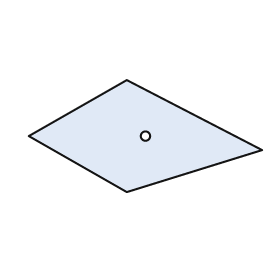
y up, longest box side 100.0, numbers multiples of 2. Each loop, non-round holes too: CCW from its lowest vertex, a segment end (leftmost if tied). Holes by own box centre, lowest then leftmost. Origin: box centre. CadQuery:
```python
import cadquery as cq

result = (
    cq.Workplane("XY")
    .moveTo(-8.0, -24.0)
    .lineTo(50.0, -6.0)
    .lineTo(-8.0, 24.0)
    .lineTo(-50.0, 0.0)
    .close()
    .moveTo(0.0, 0.0)
    .circle(2.0)
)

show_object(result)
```